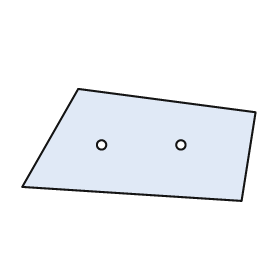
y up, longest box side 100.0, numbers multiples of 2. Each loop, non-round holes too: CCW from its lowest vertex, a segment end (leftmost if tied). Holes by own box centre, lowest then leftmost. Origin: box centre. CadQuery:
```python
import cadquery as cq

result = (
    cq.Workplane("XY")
    .moveTo(44.0, -24.0)
    .lineTo(50.0, 14.0)
    .lineTo(-26.0, 24.0)
    .lineTo(-50.0, -18.0)
    .close()
    .moveTo(-16.0, 0.0)
    .circle(2.0)
    .moveTo(18.0, 0.0)
    .circle(2.0)
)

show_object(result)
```